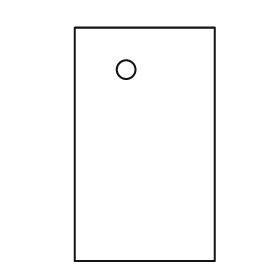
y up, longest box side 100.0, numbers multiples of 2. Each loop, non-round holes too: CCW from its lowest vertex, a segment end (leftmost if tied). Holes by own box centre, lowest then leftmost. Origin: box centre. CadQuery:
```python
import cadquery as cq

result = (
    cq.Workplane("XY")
    .moveTo(-30.0, -50.0)
    .lineTo(30.0, -50.0)
    .lineTo(30.0, 50.0)
    .lineTo(-30.0, 50.0)
    .close()
    .moveTo(-8.0, 32.0)
    .circle(4.0)
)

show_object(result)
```